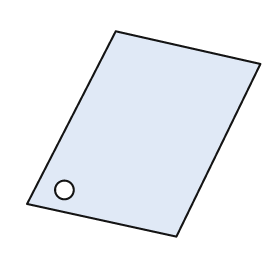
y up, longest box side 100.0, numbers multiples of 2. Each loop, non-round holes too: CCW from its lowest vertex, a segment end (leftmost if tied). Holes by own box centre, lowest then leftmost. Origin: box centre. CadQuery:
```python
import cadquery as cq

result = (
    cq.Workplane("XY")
    .moveTo(14.0, -44.0)
    .lineTo(50.0, 30.0)
    .lineTo(-12.0, 44.0)
    .lineTo(-50.0, -30.0)
    .close()
    .moveTo(-34.0, -24.0)
    .circle(4.0)
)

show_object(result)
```